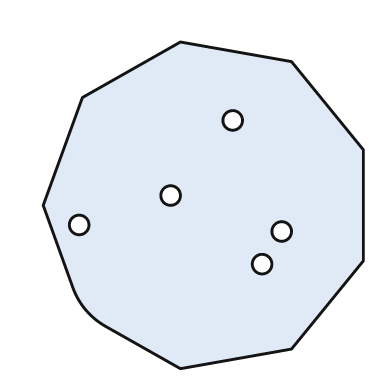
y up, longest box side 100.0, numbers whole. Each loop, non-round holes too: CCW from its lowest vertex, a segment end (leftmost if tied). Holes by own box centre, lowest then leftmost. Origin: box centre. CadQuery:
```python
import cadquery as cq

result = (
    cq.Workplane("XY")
    .moveTo(-7.0, -50.0)
    .lineTo(27.0, -44.0)
    .lineTo(49.0, -17.0)
    .lineTo(49.0, 17.0)
    .lineTo(27.0, 44.0)
    .lineTo(-7.0, 50.0)
    .lineTo(-37.0, 33.0)
    .lineTo(-49.0, 0.0)
    .lineTo(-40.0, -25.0)
    .threePointArc((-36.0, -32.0), (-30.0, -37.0))
    .close()
    .moveTo(18.0, -18.0)
    .circle(3.0)
    .moveTo(24.0, -8.0)
    .circle(3.0)
    .moveTo(-38.0, -6.0)
    .circle(3.0)
    .moveTo(-10.0, 3.0)
    .circle(3.0)
    .moveTo(9.0, 26.0)
    .circle(3.0)
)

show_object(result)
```